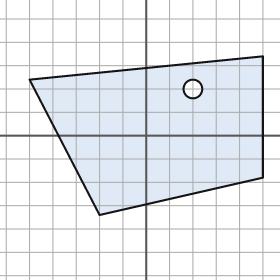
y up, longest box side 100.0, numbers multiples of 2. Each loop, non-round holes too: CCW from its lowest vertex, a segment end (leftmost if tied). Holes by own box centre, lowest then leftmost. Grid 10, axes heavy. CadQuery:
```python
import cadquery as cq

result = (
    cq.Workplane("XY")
    .moveTo(-20.0, -34.0)
    .lineTo(50.0, -18.0)
    .lineTo(50.0, 34.0)
    .lineTo(-50.0, 24.0)
    .close()
    .moveTo(20.0, 20.0)
    .circle(4.0)
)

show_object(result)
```